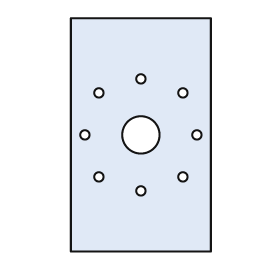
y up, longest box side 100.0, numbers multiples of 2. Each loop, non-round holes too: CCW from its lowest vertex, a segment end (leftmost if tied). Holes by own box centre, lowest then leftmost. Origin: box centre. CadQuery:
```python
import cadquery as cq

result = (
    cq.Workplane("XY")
    .moveTo(-30.0, -50.0)
    .lineTo(30.0, -50.0)
    .lineTo(30.0, 50.0)
    .lineTo(-30.0, 50.0)
    .close()
    .moveTo(0.0, -24.0)
    .circle(2.0)
    .moveTo(-18.0, -18.0)
    .circle(2.0)
    .moveTo(18.0, -18.0)
    .circle(2.0)
    .moveTo(-24.0, 0.0)
    .circle(2.0)
    .moveTo(0.0, 0.0)
    .circle(8.0)
    .moveTo(24.0, 0.0)
    .circle(2.0)
    .moveTo(-18.0, 18.0)
    .circle(2.0)
    .moveTo(18.0, 18.0)
    .circle(2.0)
    .moveTo(0.0, 24.0)
    .circle(2.0)
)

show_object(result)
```